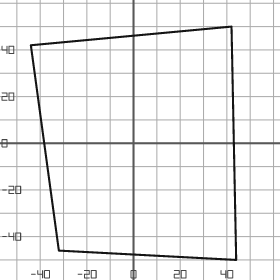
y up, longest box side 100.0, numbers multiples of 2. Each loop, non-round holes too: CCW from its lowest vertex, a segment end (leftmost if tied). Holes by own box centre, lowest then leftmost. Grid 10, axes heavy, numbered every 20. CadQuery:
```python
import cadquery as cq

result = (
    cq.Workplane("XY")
    .moveTo(44.0, -50.0)
    .lineTo(42.0, 50.0)
    .lineTo(-44.0, 42.0)
    .lineTo(-32.0, -46.0)
    .close()
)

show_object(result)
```